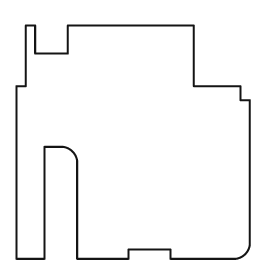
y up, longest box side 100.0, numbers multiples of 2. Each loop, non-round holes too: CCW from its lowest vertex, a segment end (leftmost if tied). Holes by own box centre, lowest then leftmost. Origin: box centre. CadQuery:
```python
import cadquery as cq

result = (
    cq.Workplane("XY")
    .moveTo(-50.0, -50.0)
    .lineTo(-38.0, -50.0)
    .lineTo(-38.0, -2.0)
    .lineTo(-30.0, -2.0)
    .threePointArc((-26.0, -4.0), (-24.0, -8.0))
    .lineTo(-24.0, -50.0)
    .lineTo(-2.0, -50.0)
    .lineTo(-2.0, -46.0)
    .lineTo(16.0, -46.0)
    .lineTo(16.0, -50.0)
    .lineTo(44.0, -50.0)
    .threePointArc((48.0, -48.0), (50.0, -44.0))
    .lineTo(50.0, 18.0)
    .lineTo(46.0, 18.0)
    .lineTo(46.0, 24.0)
    .lineTo(26.0, 24.0)
    .lineTo(26.0, 50.0)
    .lineTo(-28.0, 50.0)
    .lineTo(-28.0, 38.0)
    .lineTo(-42.0, 38.0)
    .lineTo(-42.0, 50.0)
    .lineTo(-46.0, 50.0)
    .lineTo(-46.0, 24.0)
    .lineTo(-50.0, 24.0)
    .close()
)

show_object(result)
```